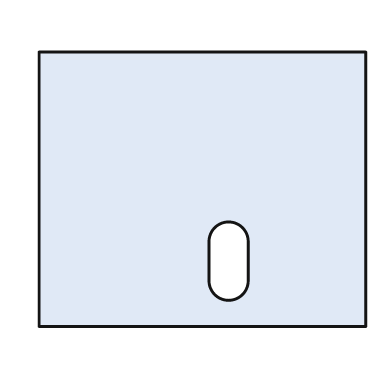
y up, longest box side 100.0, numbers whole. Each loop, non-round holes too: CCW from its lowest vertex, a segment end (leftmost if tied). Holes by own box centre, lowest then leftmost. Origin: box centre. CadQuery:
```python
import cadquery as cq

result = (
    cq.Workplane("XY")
    .moveTo(-50.0, -42.0)
    .lineTo(50.0, -42.0)
    .lineTo(50.0, 42.0)
    .lineTo(-50.0, 42.0)
    .close()
    .moveTo(2.0, -28.0)
    .threePointArc((8.0, -34.0), (14.0, -28.0))
    .lineTo(14.0, -16.0)
    .threePointArc((8.0, -10.0), (2.0, -16.0))
    .close()
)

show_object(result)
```